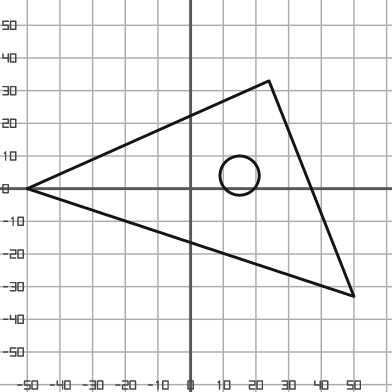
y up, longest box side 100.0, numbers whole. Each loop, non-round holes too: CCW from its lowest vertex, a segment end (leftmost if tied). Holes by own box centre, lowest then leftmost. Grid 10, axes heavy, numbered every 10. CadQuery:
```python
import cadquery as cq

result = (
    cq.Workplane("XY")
    .moveTo(50.0, -33.0)
    .lineTo(24.0, 33.0)
    .lineTo(-50.0, 0.0)
    .close()
    .moveTo(15.0, 4.0)
    .circle(6.0)
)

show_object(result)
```